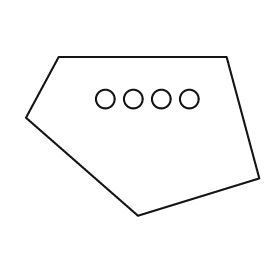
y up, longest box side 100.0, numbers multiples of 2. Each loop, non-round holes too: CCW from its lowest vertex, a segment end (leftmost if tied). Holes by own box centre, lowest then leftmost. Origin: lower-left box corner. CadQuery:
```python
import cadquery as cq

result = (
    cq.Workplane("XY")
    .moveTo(48.0, 0.0)
    .lineTo(100.0, 16.0)
    .lineTo(86.0, 68.0)
    .lineTo(14.0, 68.0)
    .lineTo(0.0, 42.0)
    .close()
    .moveTo(34.0, 50.0)
    .circle(4.0)
    .moveTo(46.0, 50.0)
    .circle(4.0)
    .moveTo(58.0, 50.0)
    .circle(4.0)
    .moveTo(70.0, 50.0)
    .circle(4.0)
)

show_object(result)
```